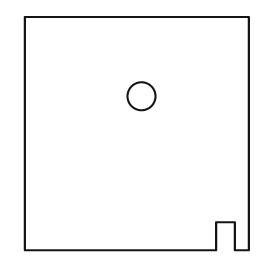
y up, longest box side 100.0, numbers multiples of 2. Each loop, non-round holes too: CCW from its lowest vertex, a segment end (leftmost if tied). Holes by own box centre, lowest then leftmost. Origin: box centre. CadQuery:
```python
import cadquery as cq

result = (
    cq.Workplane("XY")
    .moveTo(-48.0, -50.0)
    .lineTo(34.0, -50.0)
    .lineTo(34.0, -38.0)
    .lineTo(42.0, -38.0)
    .lineTo(42.0, -50.0)
    .lineTo(48.0, -50.0)
    .lineTo(48.0, 50.0)
    .lineTo(-48.0, 50.0)
    .close()
    .moveTo(2.0, 16.0)
    .circle(6.0)
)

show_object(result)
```